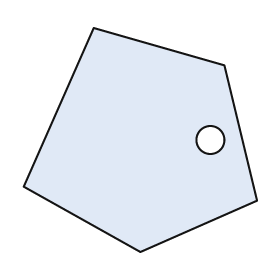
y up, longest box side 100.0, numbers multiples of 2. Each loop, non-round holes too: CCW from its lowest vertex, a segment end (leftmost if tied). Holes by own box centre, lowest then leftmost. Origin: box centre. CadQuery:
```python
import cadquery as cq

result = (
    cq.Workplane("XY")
    .moveTo(0.0, -48.0)
    .lineTo(50.0, -26.0)
    .lineTo(36.0, 32.0)
    .lineTo(-20.0, 48.0)
    .lineTo(-50.0, -20.0)
    .close()
    .moveTo(30.0, 0.0)
    .circle(6.0)
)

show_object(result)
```